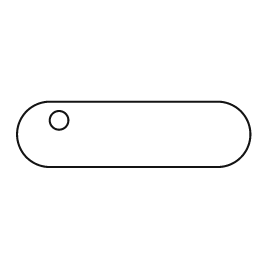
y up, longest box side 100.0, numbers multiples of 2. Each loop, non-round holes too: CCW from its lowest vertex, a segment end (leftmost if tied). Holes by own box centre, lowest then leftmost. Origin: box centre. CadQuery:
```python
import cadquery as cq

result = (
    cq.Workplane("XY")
    .moveTo(-36.0, -14.0)
    .lineTo(36.0, -14.0)
    .threePointArc((50.0, 0.0), (36.0, 14.0))
    .lineTo(-36.0, 14.0)
    .threePointArc((-50.0, 0.0), (-36.0, -14.0))
    .close()
    .moveTo(-32.0, 6.0)
    .circle(4.0)
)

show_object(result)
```